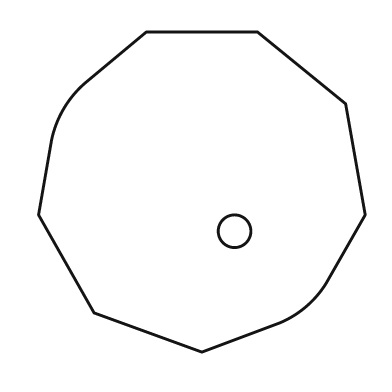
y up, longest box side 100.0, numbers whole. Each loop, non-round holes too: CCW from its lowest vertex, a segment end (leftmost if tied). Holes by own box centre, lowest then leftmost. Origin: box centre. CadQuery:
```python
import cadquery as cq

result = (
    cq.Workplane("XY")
    .moveTo(0.0, -49.0)
    .lineTo(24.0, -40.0)
    .threePointArc((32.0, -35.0), (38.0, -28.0))
    .lineTo(50.0, -7.0)
    .lineTo(44.0, 27.0)
    .lineTo(17.0, 49.0)
    .lineTo(-17.0, 49.0)
    .lineTo(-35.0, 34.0)
    .threePointArc((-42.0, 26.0), (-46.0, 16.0))
    .lineTo(-50.0, -7.0)
    .lineTo(-33.0, -37.0)
    .close()
    .moveTo(10.0, -12.0)
    .circle(5.0)
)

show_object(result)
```